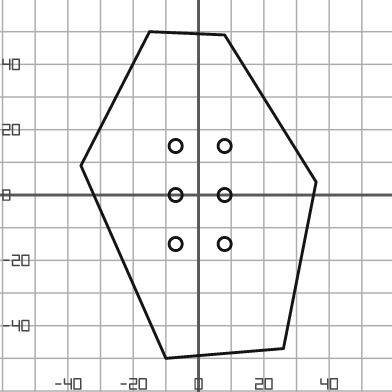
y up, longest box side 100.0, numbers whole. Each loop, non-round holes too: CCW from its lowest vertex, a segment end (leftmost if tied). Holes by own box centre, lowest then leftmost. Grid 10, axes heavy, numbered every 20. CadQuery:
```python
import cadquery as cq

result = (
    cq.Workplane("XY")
    .moveTo(-10.0, -50.0)
    .lineTo(26.0, -47.0)
    .lineTo(36.0, 4.0)
    .lineTo(8.0, 49.0)
    .lineTo(-15.0, 50.0)
    .lineTo(-36.0, 9.0)
    .close()
    .moveTo(-7.0, -15.0)
    .circle(2.0)
    .moveTo(8.0, -15.0)
    .circle(2.0)
    .moveTo(-7.0, 0.0)
    .circle(2.0)
    .moveTo(8.0, 0.0)
    .circle(2.0)
    .moveTo(-7.0, 15.0)
    .circle(2.0)
    .moveTo(8.0, 15.0)
    .circle(2.0)
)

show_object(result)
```